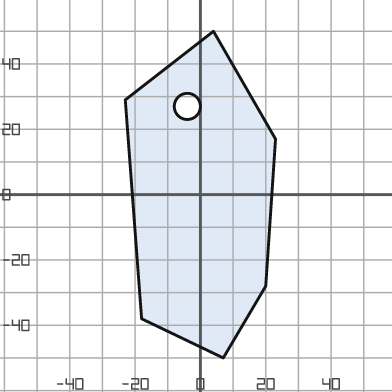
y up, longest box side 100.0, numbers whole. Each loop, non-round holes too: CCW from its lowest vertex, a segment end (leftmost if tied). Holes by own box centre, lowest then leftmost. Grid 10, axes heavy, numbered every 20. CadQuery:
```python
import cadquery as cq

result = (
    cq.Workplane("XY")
    .moveTo(7.0, -50.0)
    .lineTo(20.0, -28.0)
    .lineTo(23.0, 17.0)
    .lineTo(4.0, 50.0)
    .lineTo(-23.0, 29.0)
    .lineTo(-18.0, -38.0)
    .close()
    .moveTo(-4.0, 27.0)
    .circle(4.0)
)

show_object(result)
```